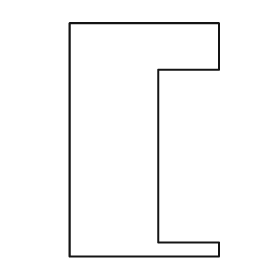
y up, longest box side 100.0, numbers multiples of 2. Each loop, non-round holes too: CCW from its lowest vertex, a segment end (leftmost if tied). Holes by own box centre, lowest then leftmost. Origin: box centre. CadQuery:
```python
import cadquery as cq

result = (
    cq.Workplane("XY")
    .moveTo(-32.0, -50.0)
    .lineTo(32.0, -50.0)
    .lineTo(32.0, -44.0)
    .lineTo(6.0, -44.0)
    .lineTo(6.0, 30.0)
    .lineTo(32.0, 30.0)
    .lineTo(32.0, 50.0)
    .lineTo(-32.0, 50.0)
    .close()
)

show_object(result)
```